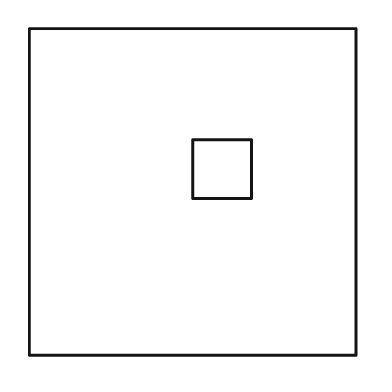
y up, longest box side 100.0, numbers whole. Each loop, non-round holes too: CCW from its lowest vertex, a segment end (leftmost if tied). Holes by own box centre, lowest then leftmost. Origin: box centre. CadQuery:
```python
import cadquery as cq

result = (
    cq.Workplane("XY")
    .moveTo(-50.0, -50.0)
    .lineTo(50.0, -50.0)
    .lineTo(50.0, 50.0)
    .lineTo(-50.0, 50.0)
    .close()
    .moveTo(0.0, -2.0)
    .lineTo(18.0, -2.0)
    .lineTo(18.0, 16.0)
    .lineTo(0.0, 16.0)
    .close()
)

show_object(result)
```